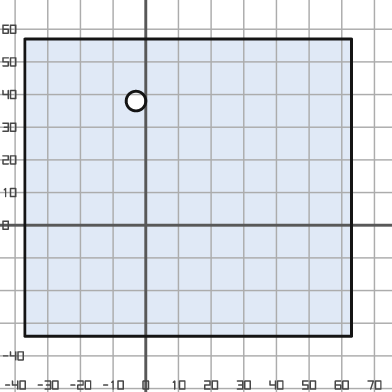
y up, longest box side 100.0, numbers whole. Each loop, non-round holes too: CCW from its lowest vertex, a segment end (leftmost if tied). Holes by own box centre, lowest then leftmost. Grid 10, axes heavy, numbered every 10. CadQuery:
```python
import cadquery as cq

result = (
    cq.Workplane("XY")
    .moveTo(-37.0, -34.0)
    .lineTo(63.0, -34.0)
    .lineTo(63.0, 57.0)
    .lineTo(-37.0, 57.0)
    .close()
    .moveTo(-3.0, 38.0)
    .circle(3.0)
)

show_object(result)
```